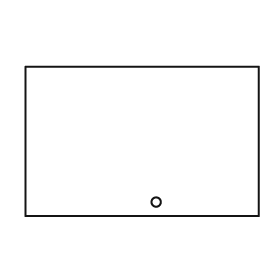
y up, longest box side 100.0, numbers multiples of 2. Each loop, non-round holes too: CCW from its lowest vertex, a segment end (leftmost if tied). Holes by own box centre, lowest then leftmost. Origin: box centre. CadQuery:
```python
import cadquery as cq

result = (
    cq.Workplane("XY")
    .moveTo(-50.0, -32.0)
    .lineTo(50.0, -32.0)
    .lineTo(50.0, 32.0)
    .lineTo(-50.0, 32.0)
    .close()
    .moveTo(6.0, -26.0)
    .circle(2.0)
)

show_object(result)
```